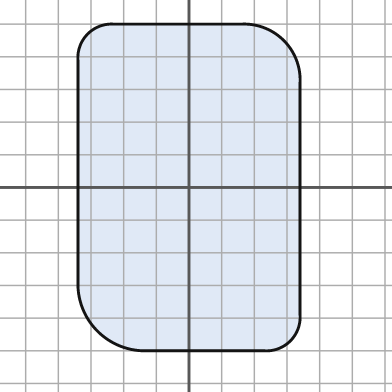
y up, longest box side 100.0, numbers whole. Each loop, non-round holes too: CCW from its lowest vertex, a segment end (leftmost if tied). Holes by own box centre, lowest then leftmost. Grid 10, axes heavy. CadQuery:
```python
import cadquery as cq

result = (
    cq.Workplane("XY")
    .moveTo(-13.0, -50.0)
    .lineTo(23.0, -50.0)
    .threePointArc((31.0, -47.0), (34.0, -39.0))
    .lineTo(34.0, 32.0)
    .threePointArc((29.0, 45.0), (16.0, 50.0))
    .lineTo(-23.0, 50.0)
    .threePointArc((-31.0, 47.0), (-34.0, 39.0))
    .lineTo(-34.0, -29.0)
    .threePointArc((-28.0, -44.0), (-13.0, -50.0))
    .close()
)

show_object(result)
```